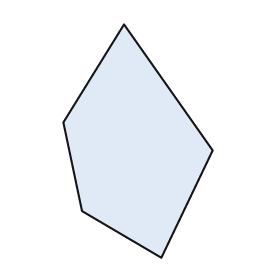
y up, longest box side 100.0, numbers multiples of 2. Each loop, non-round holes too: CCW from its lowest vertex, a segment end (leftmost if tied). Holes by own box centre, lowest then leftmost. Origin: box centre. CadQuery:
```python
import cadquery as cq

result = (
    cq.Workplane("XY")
    .moveTo(10.0, -50.0)
    .lineTo(32.0, -4.0)
    .lineTo(-6.0, 50.0)
    .lineTo(-32.0, 8.0)
    .lineTo(-24.0, -30.0)
    .close()
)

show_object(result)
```